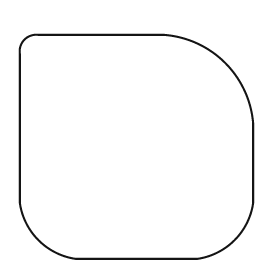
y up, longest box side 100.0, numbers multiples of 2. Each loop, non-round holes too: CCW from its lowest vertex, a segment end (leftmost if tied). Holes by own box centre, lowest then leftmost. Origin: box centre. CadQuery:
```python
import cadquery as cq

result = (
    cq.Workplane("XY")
    .moveTo(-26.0, -48.0)
    .lineTo(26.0, -48.0)
    .threePointArc((42.0, -40.0), (50.0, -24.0))
    .lineTo(50.0, 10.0)
    .threePointArc((38.0, 36.0), (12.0, 48.0))
    .lineTo(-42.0, 48.0)
    .threePointArc((-48.0, 46.0), (-50.0, 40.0))
    .lineTo(-50.0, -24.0)
    .threePointArc((-42.0, -40.0), (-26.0, -48.0))
    .close()
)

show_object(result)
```